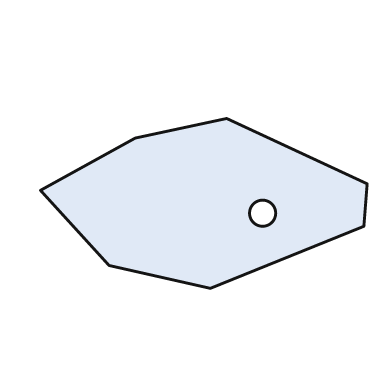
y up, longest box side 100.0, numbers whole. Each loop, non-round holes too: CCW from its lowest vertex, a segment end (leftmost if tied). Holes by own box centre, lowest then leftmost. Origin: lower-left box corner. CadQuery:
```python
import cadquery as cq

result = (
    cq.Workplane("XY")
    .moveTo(52.0, 0.0)
    .lineTo(99.0, 19.0)
    .lineTo(100.0, 32.0)
    .lineTo(57.0, 52.0)
    .lineTo(29.0, 46.0)
    .lineTo(0.0, 30.0)
    .lineTo(21.0, 7.0)
    .close()
    .moveTo(68.0, 23.0)
    .circle(4.0)
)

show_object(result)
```